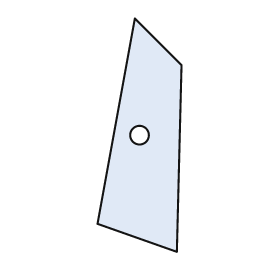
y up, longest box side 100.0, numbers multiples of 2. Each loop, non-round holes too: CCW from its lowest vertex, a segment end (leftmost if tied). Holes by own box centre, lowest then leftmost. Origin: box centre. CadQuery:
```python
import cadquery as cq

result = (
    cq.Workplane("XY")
    .moveTo(16.0, -50.0)
    .lineTo(18.0, 30.0)
    .lineTo(-2.0, 50.0)
    .lineTo(-18.0, -38.0)
    .close()
    .moveTo(0.0, 0.0)
    .circle(4.0)
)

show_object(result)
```